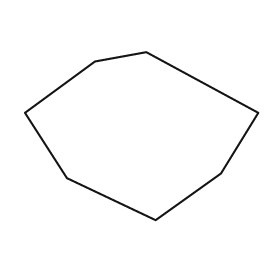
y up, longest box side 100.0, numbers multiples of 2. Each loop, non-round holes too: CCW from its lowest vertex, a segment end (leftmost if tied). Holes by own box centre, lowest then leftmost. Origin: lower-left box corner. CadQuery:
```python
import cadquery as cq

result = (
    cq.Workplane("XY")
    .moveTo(56.0, 0.0)
    .lineTo(84.0, 20.0)
    .lineTo(100.0, 46.0)
    .lineTo(52.0, 72.0)
    .lineTo(30.0, 68.0)
    .lineTo(0.0, 46.0)
    .lineTo(18.0, 18.0)
    .close()
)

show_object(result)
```